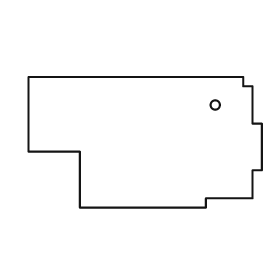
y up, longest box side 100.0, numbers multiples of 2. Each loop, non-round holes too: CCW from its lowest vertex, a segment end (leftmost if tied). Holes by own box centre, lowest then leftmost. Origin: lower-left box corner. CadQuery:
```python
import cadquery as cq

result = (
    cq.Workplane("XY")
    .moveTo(22.0, 0.0)
    .lineTo(76.0, 0.0)
    .lineTo(76.0, 4.0)
    .lineTo(96.0, 4.0)
    .lineTo(96.0, 16.0)
    .lineTo(100.0, 16.0)
    .lineTo(100.0, 36.0)
    .lineTo(96.0, 36.0)
    .lineTo(96.0, 52.0)
    .lineTo(92.0, 52.0)
    .lineTo(92.0, 56.0)
    .lineTo(0.0, 56.0)
    .lineTo(0.0, 24.0)
    .lineTo(22.0, 24.0)
    .close()
    .moveTo(80.0, 44.0)
    .circle(2.0)
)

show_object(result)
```